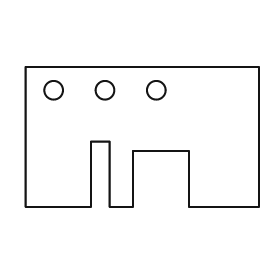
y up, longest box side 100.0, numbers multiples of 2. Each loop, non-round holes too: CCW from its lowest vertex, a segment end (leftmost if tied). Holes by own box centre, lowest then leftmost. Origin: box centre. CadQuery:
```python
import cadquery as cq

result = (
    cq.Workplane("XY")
    .moveTo(-50.0, -30.0)
    .lineTo(-22.0, -30.0)
    .lineTo(-22.0, -2.0)
    .lineTo(-14.0, -2.0)
    .lineTo(-14.0, -30.0)
    .lineTo(-4.0, -30.0)
    .lineTo(-4.0, -6.0)
    .lineTo(20.0, -6.0)
    .lineTo(20.0, -30.0)
    .lineTo(50.0, -30.0)
    .lineTo(50.0, 30.0)
    .lineTo(-50.0, 30.0)
    .close()
    .moveTo(-38.0, 20.0)
    .circle(4.0)
    .moveTo(-16.0, 20.0)
    .circle(4.0)
    .moveTo(6.0, 20.0)
    .circle(4.0)
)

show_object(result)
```